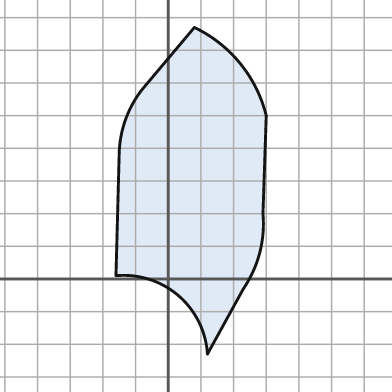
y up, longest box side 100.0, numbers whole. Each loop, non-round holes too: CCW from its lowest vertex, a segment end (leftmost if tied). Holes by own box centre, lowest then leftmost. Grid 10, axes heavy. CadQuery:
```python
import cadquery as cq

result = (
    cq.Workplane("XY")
    .moveTo(12.0, -23.0)
    .lineTo(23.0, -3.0)
    .threePointArc((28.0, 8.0), (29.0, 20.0))
    .lineTo(30.0, 50.0)
    .threePointArc((22.0, 66.0), (8.0, 77.0))
    .lineTo(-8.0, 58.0)
    .threePointArc((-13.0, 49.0), (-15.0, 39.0))
    .lineTo(-16.0, 1.0)
    .threePointArc((3.0, -5.0), (12.0, -23.0))
    .close()
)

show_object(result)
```